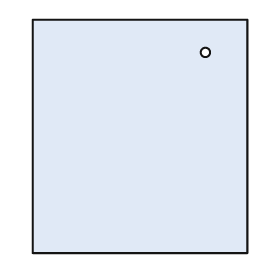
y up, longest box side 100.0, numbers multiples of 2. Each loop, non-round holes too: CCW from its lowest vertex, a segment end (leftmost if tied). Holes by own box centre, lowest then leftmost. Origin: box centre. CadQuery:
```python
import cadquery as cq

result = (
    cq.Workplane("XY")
    .moveTo(-46.0, -50.0)
    .lineTo(46.0, -50.0)
    .lineTo(46.0, 50.0)
    .lineTo(-46.0, 50.0)
    .close()
    .moveTo(28.0, 36.0)
    .circle(2.0)
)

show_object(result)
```